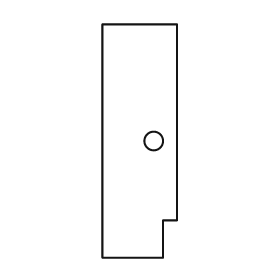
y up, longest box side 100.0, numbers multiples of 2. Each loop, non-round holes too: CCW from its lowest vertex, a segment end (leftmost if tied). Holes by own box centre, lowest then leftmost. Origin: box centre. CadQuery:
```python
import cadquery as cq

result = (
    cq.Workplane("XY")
    .moveTo(-16.0, -50.0)
    .lineTo(10.0, -50.0)
    .lineTo(10.0, -34.0)
    .lineTo(16.0, -34.0)
    .lineTo(16.0, 50.0)
    .lineTo(-16.0, 50.0)
    .close()
    .moveTo(6.0, 0.0)
    .circle(4.0)
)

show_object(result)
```